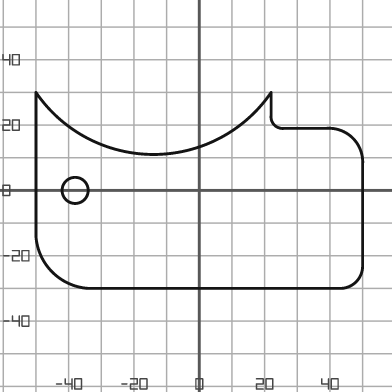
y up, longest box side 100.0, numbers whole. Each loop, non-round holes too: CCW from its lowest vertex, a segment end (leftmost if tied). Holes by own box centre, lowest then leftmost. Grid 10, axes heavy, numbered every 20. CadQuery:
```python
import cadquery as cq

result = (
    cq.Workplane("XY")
    .moveTo(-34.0, -30.0)
    .lineTo(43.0, -30.0)
    .threePointArc((48.0, -28.0), (50.0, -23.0))
    .lineTo(50.0, 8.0)
    .threePointArc((47.0, 16.0), (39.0, 19.0))
    .lineTo(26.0, 19.0)
    .threePointArc((23.0, 20.0), (22.0, 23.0))
    .lineTo(22.0, 30.0)
    .threePointArc((-14.0, 11.0), (-50.0, 30.0))
    .lineTo(-50.0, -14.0)
    .threePointArc((-45.0, -25.0), (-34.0, -30.0))
    .close()
    .moveTo(-38.0, 0.0)
    .circle(4.0)
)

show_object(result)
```